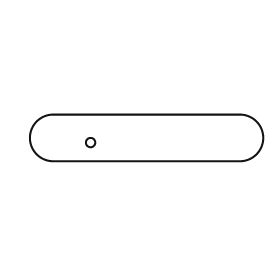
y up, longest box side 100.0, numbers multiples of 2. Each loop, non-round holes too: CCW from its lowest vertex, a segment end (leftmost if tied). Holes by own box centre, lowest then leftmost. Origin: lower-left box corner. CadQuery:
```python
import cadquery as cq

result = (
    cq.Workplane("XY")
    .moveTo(10.0, 0.0)
    .lineTo(90.0, 0.0)
    .threePointArc((100.0, 10.0), (90.0, 20.0))
    .lineTo(10.0, 20.0)
    .threePointArc((0.0, 10.0), (10.0, 0.0))
    .close()
    .moveTo(26.0, 8.0)
    .circle(2.0)
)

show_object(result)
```